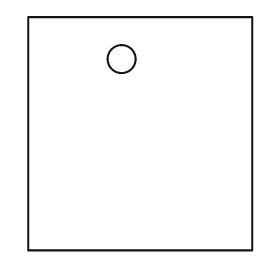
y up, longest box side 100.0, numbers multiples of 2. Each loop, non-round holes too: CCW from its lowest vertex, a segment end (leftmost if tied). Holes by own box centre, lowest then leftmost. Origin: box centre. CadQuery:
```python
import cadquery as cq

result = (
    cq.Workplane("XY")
    .moveTo(-48.0, -50.0)
    .lineTo(48.0, -50.0)
    .lineTo(48.0, 50.0)
    .lineTo(-48.0, 50.0)
    .close()
    .moveTo(-8.0, 32.0)
    .circle(6.0)
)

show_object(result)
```